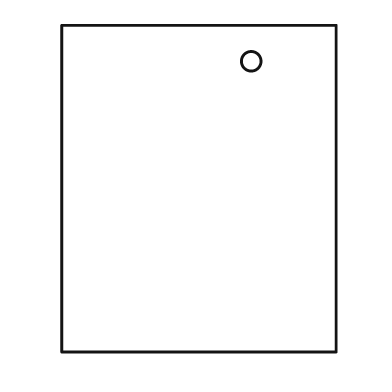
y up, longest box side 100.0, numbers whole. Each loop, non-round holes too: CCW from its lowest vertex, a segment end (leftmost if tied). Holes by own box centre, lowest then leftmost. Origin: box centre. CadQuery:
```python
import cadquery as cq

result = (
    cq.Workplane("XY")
    .moveTo(-42.0, -50.0)
    .lineTo(42.0, -50.0)
    .lineTo(42.0, 50.0)
    .lineTo(-42.0, 50.0)
    .close()
    .moveTo(16.0, 39.0)
    .circle(3.0)
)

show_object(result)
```